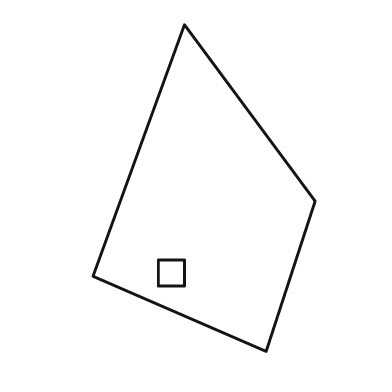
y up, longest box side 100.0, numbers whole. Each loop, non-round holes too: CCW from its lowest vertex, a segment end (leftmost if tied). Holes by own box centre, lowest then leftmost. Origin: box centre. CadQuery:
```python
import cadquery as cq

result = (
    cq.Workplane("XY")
    .moveTo(19.0, -50.0)
    .lineTo(34.0, -4.0)
    .lineTo(-6.0, 50.0)
    .lineTo(-34.0, -27.0)
    .close()
    .moveTo(-14.0, -30.0)
    .lineTo(-6.0, -30.0)
    .lineTo(-6.0, -22.0)
    .lineTo(-14.0, -22.0)
    .close()
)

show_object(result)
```